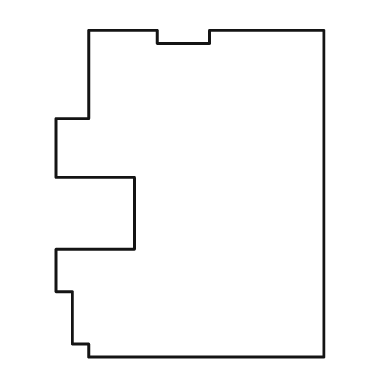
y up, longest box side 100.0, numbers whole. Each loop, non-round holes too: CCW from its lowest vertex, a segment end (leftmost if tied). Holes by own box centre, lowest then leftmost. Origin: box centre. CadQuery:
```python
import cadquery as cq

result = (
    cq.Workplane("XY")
    .moveTo(-31.0, -50.0)
    .lineTo(41.0, -50.0)
    .lineTo(41.0, 50.0)
    .lineTo(6.0, 50.0)
    .lineTo(6.0, 46.0)
    .lineTo(-10.0, 46.0)
    .lineTo(-10.0, 50.0)
    .lineTo(-31.0, 50.0)
    .lineTo(-31.0, 23.0)
    .lineTo(-41.0, 23.0)
    .lineTo(-41.0, 5.0)
    .lineTo(-17.0, 5.0)
    .lineTo(-17.0, -17.0)
    .lineTo(-41.0, -17.0)
    .lineTo(-41.0, -30.0)
    .lineTo(-36.0, -30.0)
    .lineTo(-36.0, -46.0)
    .lineTo(-31.0, -46.0)
    .close()
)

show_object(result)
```